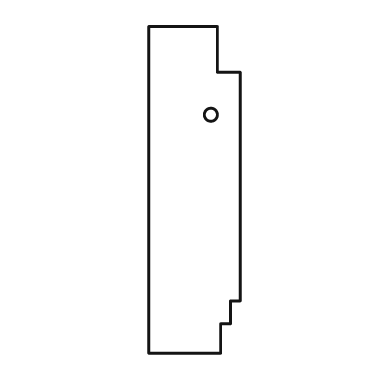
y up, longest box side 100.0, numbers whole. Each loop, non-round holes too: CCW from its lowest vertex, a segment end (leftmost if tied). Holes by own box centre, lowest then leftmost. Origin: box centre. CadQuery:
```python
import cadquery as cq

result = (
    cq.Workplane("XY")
    .moveTo(-14.0, -50.0)
    .lineTo(8.0, -50.0)
    .lineTo(8.0, -41.0)
    .lineTo(11.0, -41.0)
    .lineTo(11.0, -34.0)
    .lineTo(14.0, -34.0)
    .lineTo(14.0, 36.0)
    .lineTo(7.0, 36.0)
    .lineTo(7.0, 50.0)
    .lineTo(-14.0, 50.0)
    .close()
    .moveTo(5.0, 23.0)
    .circle(2.0)
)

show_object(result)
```